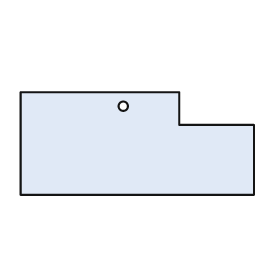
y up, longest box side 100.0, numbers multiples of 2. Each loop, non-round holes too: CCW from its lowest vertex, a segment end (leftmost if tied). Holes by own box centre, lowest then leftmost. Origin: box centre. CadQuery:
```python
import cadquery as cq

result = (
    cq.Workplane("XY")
    .moveTo(-50.0, -22.0)
    .lineTo(50.0, -22.0)
    .lineTo(50.0, 8.0)
    .lineTo(18.0, 8.0)
    .lineTo(18.0, 22.0)
    .lineTo(-50.0, 22.0)
    .close()
    .moveTo(-6.0, 16.0)
    .circle(2.0)
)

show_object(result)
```